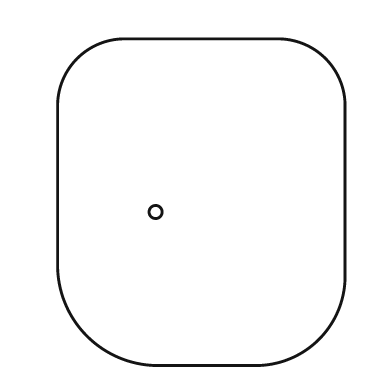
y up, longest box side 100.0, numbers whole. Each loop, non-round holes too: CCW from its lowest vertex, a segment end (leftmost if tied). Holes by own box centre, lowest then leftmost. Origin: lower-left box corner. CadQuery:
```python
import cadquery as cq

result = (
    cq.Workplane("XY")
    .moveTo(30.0, 0.0)
    .lineTo(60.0, 0.0)
    .threePointArc((80.0, 8.0), (88.0, 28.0))
    .lineTo(88.0, 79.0)
    .threePointArc((82.0, 94.0), (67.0, 100.0))
    .lineTo(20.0, 100.0)
    .threePointArc((6.0, 94.0), (0.0, 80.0))
    .lineTo(0.0, 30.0)
    .threePointArc((9.0, 9.0), (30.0, 0.0))
    .close()
    .moveTo(30.0, 47.0)
    .circle(2.0)
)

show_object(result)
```